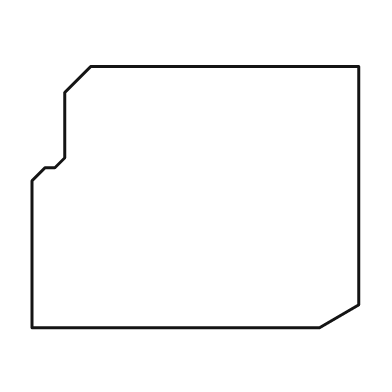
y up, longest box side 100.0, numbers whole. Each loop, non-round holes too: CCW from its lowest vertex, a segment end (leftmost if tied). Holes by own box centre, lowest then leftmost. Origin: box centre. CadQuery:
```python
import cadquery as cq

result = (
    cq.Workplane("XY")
    .moveTo(-50.0, -40.0)
    .lineTo(38.0, -40.0)
    .lineTo(50.0, -33.0)
    .lineTo(50.0, 40.0)
    .lineTo(-32.0, 40.0)
    .lineTo(-40.0, 32.0)
    .lineTo(-40.0, 12.0)
    .lineTo(-43.0, 9.0)
    .lineTo(-46.0, 9.0)
    .lineTo(-50.0, 5.0)
    .close()
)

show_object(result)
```